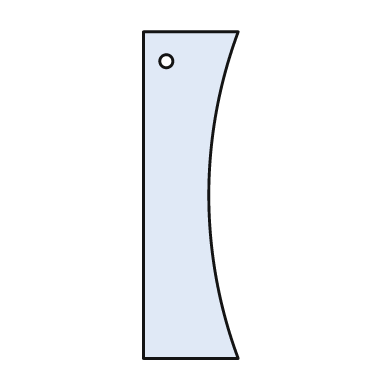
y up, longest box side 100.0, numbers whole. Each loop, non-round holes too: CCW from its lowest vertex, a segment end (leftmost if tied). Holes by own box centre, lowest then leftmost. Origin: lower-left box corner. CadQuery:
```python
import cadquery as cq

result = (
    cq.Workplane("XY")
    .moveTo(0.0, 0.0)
    .lineTo(29.0, 0.0)
    .threePointArc((20.0, 50.0), (29.0, 100.0))
    .lineTo(0.0, 100.0)
    .close()
    .moveTo(7.0, 91.0)
    .circle(2.0)
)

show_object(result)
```